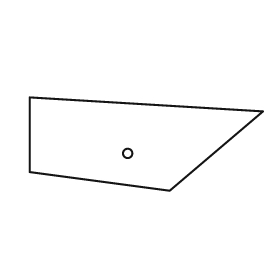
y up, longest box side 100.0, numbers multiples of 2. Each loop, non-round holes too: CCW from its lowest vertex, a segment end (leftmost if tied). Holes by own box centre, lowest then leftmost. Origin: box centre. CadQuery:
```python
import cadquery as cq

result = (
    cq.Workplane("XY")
    .moveTo(10.0, -20.0)
    .lineTo(50.0, 14.0)
    .lineTo(-50.0, 20.0)
    .lineTo(-50.0, -12.0)
    .close()
    .moveTo(-8.0, -4.0)
    .circle(2.0)
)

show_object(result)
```